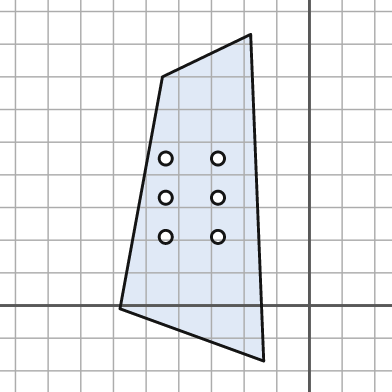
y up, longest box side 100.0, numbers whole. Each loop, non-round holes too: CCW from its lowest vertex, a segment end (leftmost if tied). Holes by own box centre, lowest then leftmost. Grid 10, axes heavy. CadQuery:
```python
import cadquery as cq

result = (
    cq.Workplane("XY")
    .moveTo(-14.0, -17.0)
    .lineTo(-18.0, 83.0)
    .lineTo(-45.0, 70.0)
    .lineTo(-58.0, -1.0)
    .close()
    .moveTo(-44.0, 21.0)
    .circle(2.0)
    .moveTo(-28.0, 21.0)
    .circle(2.0)
    .moveTo(-44.0, 33.0)
    .circle(2.0)
    .moveTo(-28.0, 33.0)
    .circle(2.0)
    .moveTo(-44.0, 45.0)
    .circle(2.0)
    .moveTo(-28.0, 45.0)
    .circle(2.0)
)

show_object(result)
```